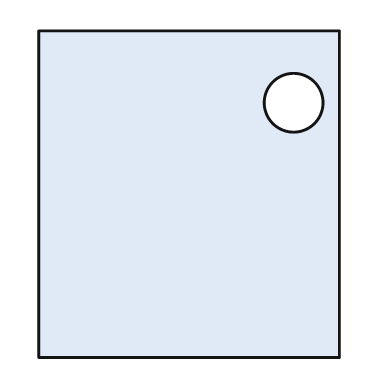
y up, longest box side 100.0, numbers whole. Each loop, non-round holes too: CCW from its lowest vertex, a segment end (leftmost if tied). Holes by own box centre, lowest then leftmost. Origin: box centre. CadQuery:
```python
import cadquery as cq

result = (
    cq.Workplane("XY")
    .moveTo(-46.0, -50.0)
    .lineTo(46.0, -50.0)
    .lineTo(46.0, 50.0)
    .lineTo(-46.0, 50.0)
    .close()
    .moveTo(32.0, 28.0)
    .circle(9.0)
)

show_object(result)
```